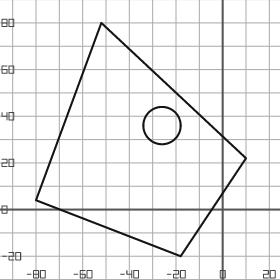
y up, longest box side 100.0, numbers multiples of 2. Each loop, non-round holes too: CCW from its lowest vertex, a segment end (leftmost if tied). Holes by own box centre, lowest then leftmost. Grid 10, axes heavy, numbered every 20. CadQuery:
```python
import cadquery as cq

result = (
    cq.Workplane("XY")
    .moveTo(-18.0, -20.0)
    .lineTo(10.0, 22.0)
    .lineTo(-52.0, 80.0)
    .lineTo(-80.0, 4.0)
    .close()
    .moveTo(-26.0, 36.0)
    .circle(8.0)
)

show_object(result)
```